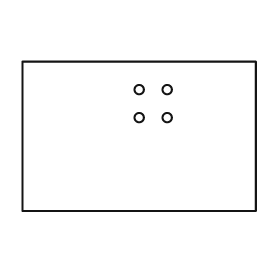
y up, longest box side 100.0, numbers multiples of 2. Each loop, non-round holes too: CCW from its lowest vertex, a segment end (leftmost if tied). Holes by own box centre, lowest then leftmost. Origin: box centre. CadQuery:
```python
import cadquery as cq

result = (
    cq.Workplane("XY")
    .moveTo(-50.0, -32.0)
    .lineTo(50.0, -32.0)
    .lineTo(50.0, 32.0)
    .lineTo(-50.0, 32.0)
    .close()
    .moveTo(0.0, 8.0)
    .circle(2.0)
    .moveTo(12.0, 8.0)
    .circle(2.0)
    .moveTo(0.0, 20.0)
    .circle(2.0)
    .moveTo(12.0, 20.0)
    .circle(2.0)
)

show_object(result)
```